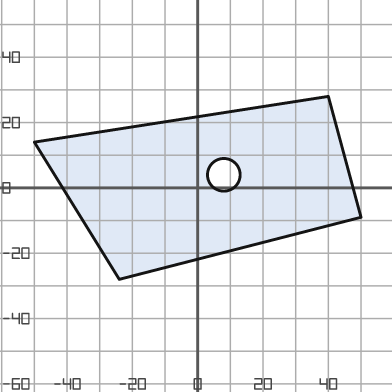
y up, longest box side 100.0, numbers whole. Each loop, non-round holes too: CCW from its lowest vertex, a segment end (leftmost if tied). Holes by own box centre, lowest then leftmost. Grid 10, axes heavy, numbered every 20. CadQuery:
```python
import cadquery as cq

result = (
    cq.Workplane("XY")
    .moveTo(-24.0, -28.0)
    .lineTo(50.0, -9.0)
    .lineTo(40.0, 28.0)
    .lineTo(-50.0, 14.0)
    .close()
    .moveTo(8.0, 4.0)
    .circle(5.0)
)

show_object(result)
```